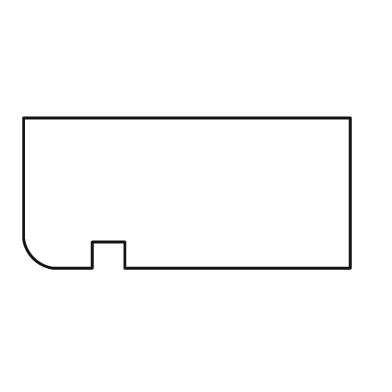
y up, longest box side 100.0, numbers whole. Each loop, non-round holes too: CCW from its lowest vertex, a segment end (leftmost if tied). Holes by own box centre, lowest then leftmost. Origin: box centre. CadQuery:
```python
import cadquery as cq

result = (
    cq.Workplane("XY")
    .moveTo(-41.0, -23.0)
    .lineTo(-29.0, -23.0)
    .lineTo(-29.0, -15.0)
    .lineTo(-19.0, -15.0)
    .lineTo(-19.0, -23.0)
    .lineTo(50.0, -23.0)
    .lineTo(50.0, 23.0)
    .lineTo(-50.0, 23.0)
    .lineTo(-50.0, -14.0)
    .threePointArc((-47.0, -20.0), (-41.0, -23.0))
    .close()
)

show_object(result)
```